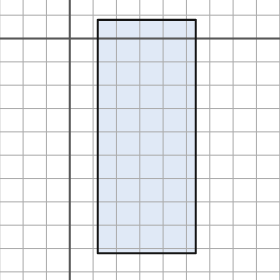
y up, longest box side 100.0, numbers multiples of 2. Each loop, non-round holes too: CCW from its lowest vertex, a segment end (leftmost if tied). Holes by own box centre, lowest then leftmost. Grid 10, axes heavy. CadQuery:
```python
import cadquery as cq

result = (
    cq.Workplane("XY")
    .moveTo(12.0, -92.0)
    .lineTo(54.0, -92.0)
    .lineTo(54.0, 8.0)
    .lineTo(12.0, 8.0)
    .close()
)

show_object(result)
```